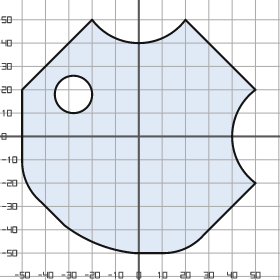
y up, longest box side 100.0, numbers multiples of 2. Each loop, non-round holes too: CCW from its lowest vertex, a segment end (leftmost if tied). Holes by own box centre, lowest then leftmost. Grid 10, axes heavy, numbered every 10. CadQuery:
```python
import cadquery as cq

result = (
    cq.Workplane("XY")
    .moveTo(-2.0, -50.0)
    .lineTo(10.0, -50.0)
    .threePointArc((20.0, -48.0), (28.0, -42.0))
    .lineTo(50.0, -20.0)
    .threePointArc((40.0, 0.0), (50.0, 20.0))
    .lineTo(20.0, 50.0)
    .threePointArc((0.0, 40.0), (-20.0, 50.0))
    .lineTo(-50.0, 20.0)
    .lineTo(-50.0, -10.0)
    .threePointArc((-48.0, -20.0), (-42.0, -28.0))
    .lineTo(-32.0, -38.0)
    .threePointArc((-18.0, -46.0), (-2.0, -50.0))
    .close()
    .moveTo(-28.0, 18.0)
    .circle(8.0)
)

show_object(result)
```